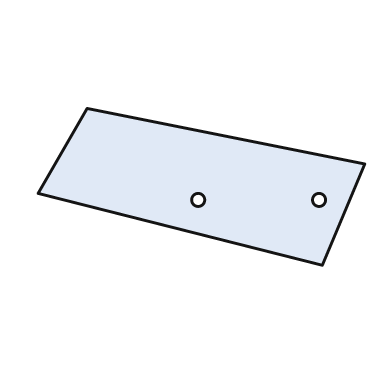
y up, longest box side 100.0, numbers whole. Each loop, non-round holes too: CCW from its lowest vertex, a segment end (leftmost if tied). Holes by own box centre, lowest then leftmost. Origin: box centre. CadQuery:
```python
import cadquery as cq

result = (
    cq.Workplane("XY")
    .moveTo(37.0, -24.0)
    .lineTo(50.0, 7.0)
    .lineTo(-35.0, 24.0)
    .lineTo(-50.0, -2.0)
    .close()
    .moveTo(-1.0, -4.0)
    .circle(2.0)
    .moveTo(36.0, -4.0)
    .circle(2.0)
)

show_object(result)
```